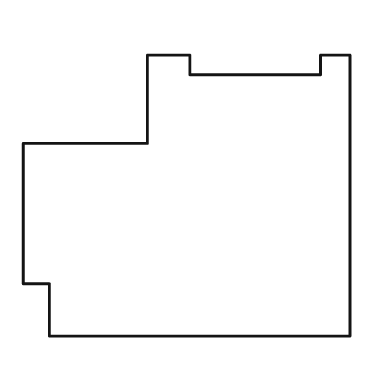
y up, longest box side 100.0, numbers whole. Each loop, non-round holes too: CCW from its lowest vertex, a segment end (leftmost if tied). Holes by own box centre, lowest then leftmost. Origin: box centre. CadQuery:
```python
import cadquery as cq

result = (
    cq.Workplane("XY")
    .moveTo(-42.0, -43.0)
    .lineTo(50.0, -43.0)
    .lineTo(50.0, 43.0)
    .lineTo(41.0, 43.0)
    .lineTo(41.0, 37.0)
    .lineTo(1.0, 37.0)
    .lineTo(1.0, 43.0)
    .lineTo(-12.0, 43.0)
    .lineTo(-12.0, 16.0)
    .lineTo(-50.0, 16.0)
    .lineTo(-50.0, -27.0)
    .lineTo(-42.0, -27.0)
    .close()
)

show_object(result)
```